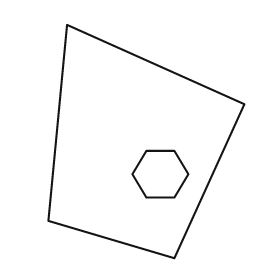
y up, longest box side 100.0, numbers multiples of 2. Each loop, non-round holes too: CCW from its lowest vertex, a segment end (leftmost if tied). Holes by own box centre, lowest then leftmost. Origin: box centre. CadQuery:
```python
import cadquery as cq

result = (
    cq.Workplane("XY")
    .moveTo(12.0, -50.0)
    .lineTo(42.0, 16.0)
    .lineTo(-34.0, 50.0)
    .lineTo(-42.0, -34.0)
    .close()
    .moveTo(0.0, -24.0)
    .lineTo(12.0, -24.0)
    .lineTo(18.0, -14.0)
    .lineTo(12.0, -4.0)
    .lineTo(0.0, -4.0)
    .lineTo(-6.0, -14.0)
    .close()
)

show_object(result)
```